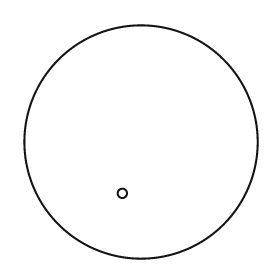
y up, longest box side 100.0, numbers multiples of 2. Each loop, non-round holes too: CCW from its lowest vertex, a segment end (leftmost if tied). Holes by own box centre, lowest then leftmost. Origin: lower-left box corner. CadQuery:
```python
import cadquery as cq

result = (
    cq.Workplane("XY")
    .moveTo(50.0, 50.0)
    .circle(50.0)
    .moveTo(42.0, 28.0)
    .circle(2.0)
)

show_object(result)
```